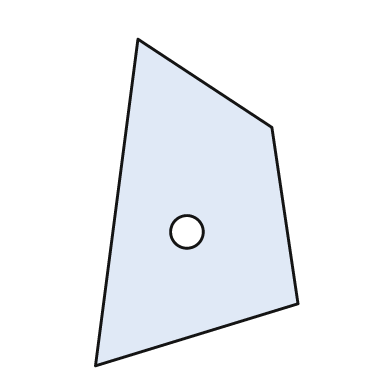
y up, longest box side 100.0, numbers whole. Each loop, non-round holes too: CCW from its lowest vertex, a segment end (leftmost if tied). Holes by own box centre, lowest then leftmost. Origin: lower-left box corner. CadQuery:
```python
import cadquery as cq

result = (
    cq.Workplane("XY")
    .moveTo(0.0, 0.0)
    .lineTo(62.0, 19.0)
    .lineTo(54.0, 73.0)
    .lineTo(13.0, 100.0)
    .close()
    .moveTo(28.0, 41.0)
    .circle(5.0)
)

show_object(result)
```